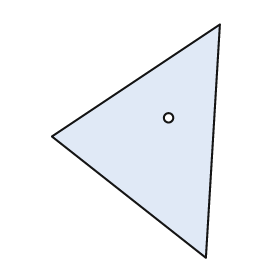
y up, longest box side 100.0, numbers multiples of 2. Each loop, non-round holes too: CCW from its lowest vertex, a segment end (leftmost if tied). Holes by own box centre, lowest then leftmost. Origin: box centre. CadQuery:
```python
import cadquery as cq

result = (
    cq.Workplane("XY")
    .moveTo(30.0, -50.0)
    .lineTo(36.0, 50.0)
    .lineTo(-36.0, 2.0)
    .close()
    .moveTo(14.0, 10.0)
    .circle(2.0)
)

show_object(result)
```